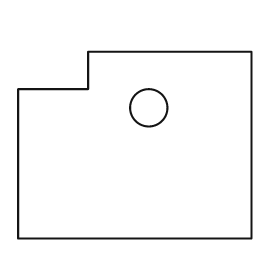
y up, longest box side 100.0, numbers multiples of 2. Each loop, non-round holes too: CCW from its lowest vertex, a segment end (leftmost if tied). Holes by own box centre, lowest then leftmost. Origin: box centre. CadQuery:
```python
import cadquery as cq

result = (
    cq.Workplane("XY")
    .moveTo(-50.0, -40.0)
    .lineTo(50.0, -40.0)
    .lineTo(50.0, 40.0)
    .lineTo(-20.0, 40.0)
    .lineTo(-20.0, 24.0)
    .lineTo(-50.0, 24.0)
    .close()
    .moveTo(6.0, 16.0)
    .circle(8.0)
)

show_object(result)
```